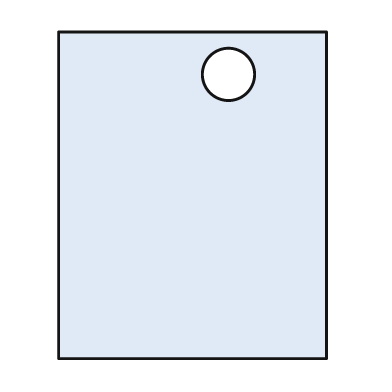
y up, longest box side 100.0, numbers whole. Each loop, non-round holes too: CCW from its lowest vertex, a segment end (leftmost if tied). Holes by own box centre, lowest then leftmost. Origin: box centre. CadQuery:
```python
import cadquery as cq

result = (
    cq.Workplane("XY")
    .moveTo(-41.0, -50.0)
    .lineTo(41.0, -50.0)
    .lineTo(41.0, 50.0)
    .lineTo(-41.0, 50.0)
    .close()
    .moveTo(11.0, 37.0)
    .circle(8.0)
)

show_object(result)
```